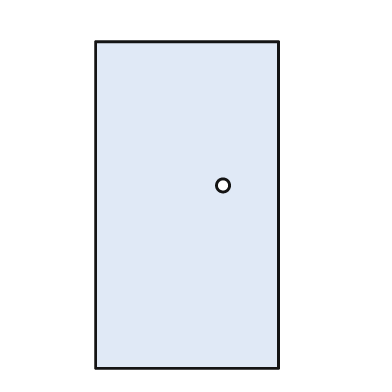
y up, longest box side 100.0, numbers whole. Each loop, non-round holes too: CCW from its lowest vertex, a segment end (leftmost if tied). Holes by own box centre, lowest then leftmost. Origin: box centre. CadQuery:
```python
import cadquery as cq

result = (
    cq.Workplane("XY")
    .moveTo(-28.0, -50.0)
    .lineTo(28.0, -50.0)
    .lineTo(28.0, 50.0)
    .lineTo(-28.0, 50.0)
    .close()
    .moveTo(11.0, 6.0)
    .circle(2.0)
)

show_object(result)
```